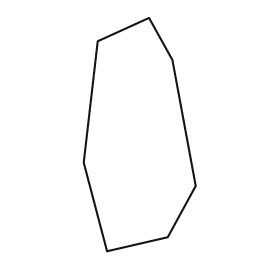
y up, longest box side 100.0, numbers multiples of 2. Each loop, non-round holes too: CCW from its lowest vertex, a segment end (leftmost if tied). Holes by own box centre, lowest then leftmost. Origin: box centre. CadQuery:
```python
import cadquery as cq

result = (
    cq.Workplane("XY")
    .moveTo(-14.0, -50.0)
    .lineTo(12.0, -44.0)
    .lineTo(24.0, -22.0)
    .lineTo(14.0, 32.0)
    .lineTo(4.0, 50.0)
    .lineTo(-18.0, 40.0)
    .lineTo(-24.0, -12.0)
    .close()
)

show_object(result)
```